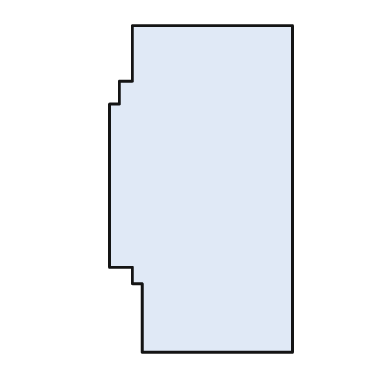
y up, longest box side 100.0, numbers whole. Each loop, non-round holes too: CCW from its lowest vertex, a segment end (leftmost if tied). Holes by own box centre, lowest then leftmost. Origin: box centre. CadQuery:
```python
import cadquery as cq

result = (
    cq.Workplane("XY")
    .moveTo(-18.0, -50.0)
    .lineTo(28.0, -50.0)
    .lineTo(28.0, 50.0)
    .lineTo(-21.0, 50.0)
    .lineTo(-21.0, 33.0)
    .lineTo(-25.0, 33.0)
    .lineTo(-25.0, 26.0)
    .lineTo(-28.0, 26.0)
    .lineTo(-28.0, -24.0)
    .lineTo(-21.0, -24.0)
    .lineTo(-21.0, -29.0)
    .lineTo(-18.0, -29.0)
    .close()
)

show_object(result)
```